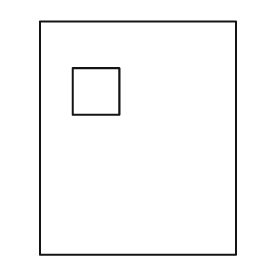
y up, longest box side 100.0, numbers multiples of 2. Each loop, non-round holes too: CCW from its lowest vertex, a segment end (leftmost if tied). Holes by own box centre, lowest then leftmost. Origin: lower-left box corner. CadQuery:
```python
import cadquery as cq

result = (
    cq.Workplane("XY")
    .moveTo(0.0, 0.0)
    .lineTo(84.0, 0.0)
    .lineTo(84.0, 100.0)
    .lineTo(0.0, 100.0)
    .close()
    .moveTo(14.0, 60.0)
    .lineTo(34.0, 60.0)
    .lineTo(34.0, 80.0)
    .lineTo(14.0, 80.0)
    .close()
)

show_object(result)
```